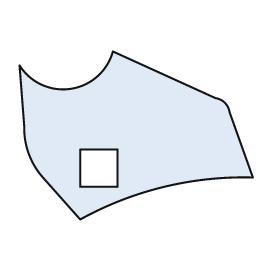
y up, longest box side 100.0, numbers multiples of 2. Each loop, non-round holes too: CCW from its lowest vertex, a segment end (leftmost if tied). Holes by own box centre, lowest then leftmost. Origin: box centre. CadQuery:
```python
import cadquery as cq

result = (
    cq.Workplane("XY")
    .moveTo(-24.0, -36.0)
    .threePointArc((12.0, -22.0), (50.0, -18.0))
    .lineTo(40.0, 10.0)
    .threePointArc((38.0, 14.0), (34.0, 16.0))
    .lineTo(-10.0, 36.0)
    .threePointArc((-28.0, 20.0), (-50.0, 30.0))
    .lineTo(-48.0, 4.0)
    .threePointArc((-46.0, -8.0), (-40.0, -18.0))
    .close()
    .moveTo(-24.0, -22.0)
    .lineTo(-8.0, -22.0)
    .lineTo(-8.0, -6.0)
    .lineTo(-24.0, -6.0)
    .close()
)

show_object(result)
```